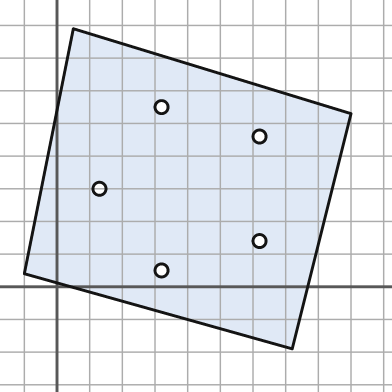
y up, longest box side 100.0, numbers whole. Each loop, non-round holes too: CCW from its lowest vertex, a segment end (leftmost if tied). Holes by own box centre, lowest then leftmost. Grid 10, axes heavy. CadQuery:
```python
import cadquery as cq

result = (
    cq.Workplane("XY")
    .moveTo(72.0, -19.0)
    .lineTo(90.0, 53.0)
    .lineTo(5.0, 79.0)
    .lineTo(-10.0, 4.0)
    .close()
    .moveTo(32.0, 5.0)
    .circle(2.0)
    .moveTo(62.0, 14.0)
    .circle(2.0)
    .moveTo(13.0, 30.0)
    .circle(2.0)
    .moveTo(62.0, 46.0)
    .circle(2.0)
    .moveTo(32.0, 55.0)
    .circle(2.0)
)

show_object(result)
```